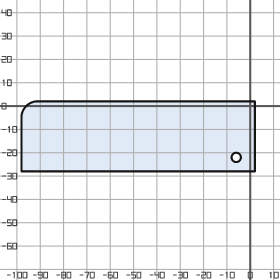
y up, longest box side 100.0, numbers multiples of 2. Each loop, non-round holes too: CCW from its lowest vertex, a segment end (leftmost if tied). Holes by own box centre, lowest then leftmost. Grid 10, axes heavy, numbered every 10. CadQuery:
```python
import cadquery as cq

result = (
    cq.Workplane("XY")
    .moveTo(-98.0, -28.0)
    .lineTo(2.0, -28.0)
    .lineTo(2.0, 2.0)
    .lineTo(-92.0, 2.0)
    .threePointArc((-96.0, 0.0), (-98.0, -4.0))
    .close()
    .moveTo(-6.0, -22.0)
    .circle(2.0)
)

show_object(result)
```